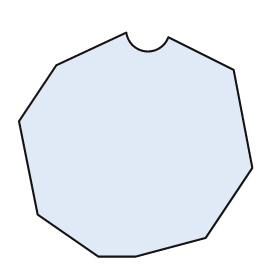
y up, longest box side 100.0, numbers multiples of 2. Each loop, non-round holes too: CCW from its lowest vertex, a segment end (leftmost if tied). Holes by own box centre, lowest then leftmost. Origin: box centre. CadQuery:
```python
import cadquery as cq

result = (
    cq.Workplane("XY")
    .moveTo(-16.0, -48.0)
    .lineTo(0.0, -48.0)
    .lineTo(30.0, -40.0)
    .lineTo(50.0, -10.0)
    .lineTo(42.0, 32.0)
    .lineTo(14.0, 46.0)
    .threePointArc((4.0, 40.0), (-4.0, 48.0))
    .lineTo(-34.0, 34.0)
    .lineTo(-50.0, 10.0)
    .lineTo(-42.0, -30.0)
    .close()
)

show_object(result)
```